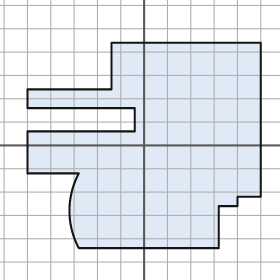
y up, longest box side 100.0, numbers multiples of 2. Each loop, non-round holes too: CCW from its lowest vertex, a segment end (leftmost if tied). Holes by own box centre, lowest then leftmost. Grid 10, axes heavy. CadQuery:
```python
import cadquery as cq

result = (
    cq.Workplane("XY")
    .moveTo(-28.0, -44.0)
    .lineTo(32.0, -44.0)
    .lineTo(32.0, -26.0)
    .lineTo(40.0, -26.0)
    .lineTo(40.0, -22.0)
    .lineTo(50.0, -22.0)
    .lineTo(50.0, 44.0)
    .lineTo(-14.0, 44.0)
    .lineTo(-14.0, 24.0)
    .lineTo(-50.0, 24.0)
    .lineTo(-50.0, 16.0)
    .lineTo(-4.0, 16.0)
    .lineTo(-4.0, 6.0)
    .lineTo(-50.0, 6.0)
    .lineTo(-50.0, -12.0)
    .lineTo(-28.0, -12.0)
    .threePointArc((-32.0, -28.0), (-28.0, -44.0))
    .close()
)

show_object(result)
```